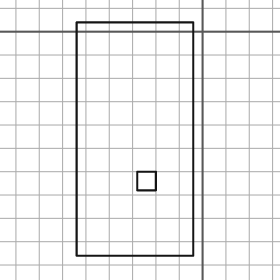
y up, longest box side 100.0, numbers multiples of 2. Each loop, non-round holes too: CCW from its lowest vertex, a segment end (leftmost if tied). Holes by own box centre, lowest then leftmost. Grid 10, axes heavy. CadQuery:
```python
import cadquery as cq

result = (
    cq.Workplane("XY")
    .moveTo(-54.0, -96.0)
    .lineTo(-4.0, -96.0)
    .lineTo(-4.0, 4.0)
    .lineTo(-54.0, 4.0)
    .close()
    .moveTo(-28.0, -68.0)
    .lineTo(-20.0, -68.0)
    .lineTo(-20.0, -60.0)
    .lineTo(-28.0, -60.0)
    .close()
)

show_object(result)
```